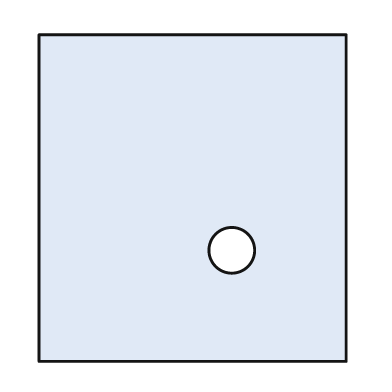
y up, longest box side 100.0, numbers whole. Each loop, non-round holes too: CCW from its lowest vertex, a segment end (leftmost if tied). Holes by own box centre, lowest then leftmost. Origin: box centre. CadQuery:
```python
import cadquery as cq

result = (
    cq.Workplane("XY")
    .moveTo(-47.0, -50.0)
    .lineTo(47.0, -50.0)
    .lineTo(47.0, 50.0)
    .lineTo(-47.0, 50.0)
    .close()
    .moveTo(12.0, -16.0)
    .circle(7.0)
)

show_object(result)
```